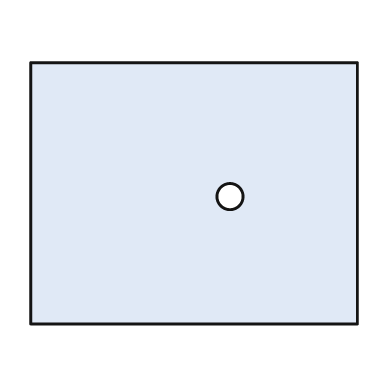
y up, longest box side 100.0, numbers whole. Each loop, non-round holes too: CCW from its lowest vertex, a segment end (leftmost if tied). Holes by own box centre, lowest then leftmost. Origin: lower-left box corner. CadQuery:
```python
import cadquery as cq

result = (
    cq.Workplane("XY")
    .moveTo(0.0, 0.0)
    .lineTo(100.0, 0.0)
    .lineTo(100.0, 80.0)
    .lineTo(0.0, 80.0)
    .close()
    .moveTo(61.0, 39.0)
    .circle(4.0)
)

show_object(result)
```